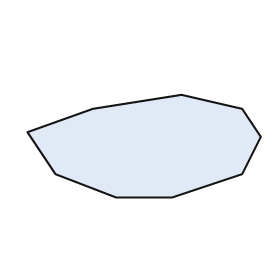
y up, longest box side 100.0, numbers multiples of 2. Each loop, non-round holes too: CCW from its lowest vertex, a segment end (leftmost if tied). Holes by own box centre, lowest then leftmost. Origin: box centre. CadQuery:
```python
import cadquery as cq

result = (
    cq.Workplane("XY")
    .moveTo(-12.0, -22.0)
    .lineTo(12.0, -22.0)
    .lineTo(42.0, -12.0)
    .lineTo(50.0, 4.0)
    .lineTo(42.0, 16.0)
    .lineTo(16.0, 22.0)
    .lineTo(-22.0, 16.0)
    .lineTo(-50.0, 6.0)
    .lineTo(-38.0, -12.0)
    .close()
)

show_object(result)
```